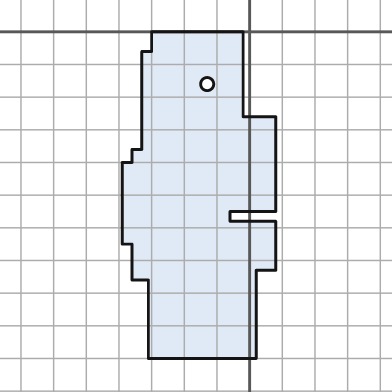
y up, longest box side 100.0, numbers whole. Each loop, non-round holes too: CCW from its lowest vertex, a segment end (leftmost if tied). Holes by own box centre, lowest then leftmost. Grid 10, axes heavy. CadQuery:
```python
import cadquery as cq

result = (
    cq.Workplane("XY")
    .moveTo(-31.0, -100.0)
    .lineTo(2.0, -100.0)
    .lineTo(2.0, -73.0)
    .lineTo(8.0, -73.0)
    .lineTo(8.0, -58.0)
    .lineTo(-6.0, -58.0)
    .lineTo(-6.0, -55.0)
    .lineTo(8.0, -55.0)
    .lineTo(8.0, -26.0)
    .lineTo(-2.0, -26.0)
    .lineTo(-2.0, 0.0)
    .lineTo(-30.0, 0.0)
    .lineTo(-30.0, -6.0)
    .lineTo(-33.0, -6.0)
    .lineTo(-33.0, -36.0)
    .lineTo(-36.0, -36.0)
    .lineTo(-36.0, -40.0)
    .lineTo(-39.0, -40.0)
    .lineTo(-39.0, -65.0)
    .lineTo(-36.0, -65.0)
    .lineTo(-36.0, -76.0)
    .lineTo(-31.0, -76.0)
    .close()
    .moveTo(-13.0, -16.0)
    .circle(2.0)
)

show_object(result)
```